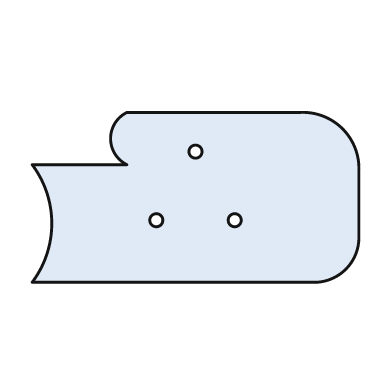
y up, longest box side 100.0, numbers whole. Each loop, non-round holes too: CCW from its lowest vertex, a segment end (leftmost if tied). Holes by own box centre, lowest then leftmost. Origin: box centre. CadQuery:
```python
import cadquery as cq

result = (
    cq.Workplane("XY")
    .moveTo(-50.0, -26.0)
    .lineTo(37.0, -26.0)
    .threePointArc((46.0, -22.0), (50.0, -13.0))
    .lineTo(50.0, 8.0)
    .threePointArc((45.0, 21.0), (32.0, 26.0))
    .lineTo(-21.0, 26.0)
    .threePointArc((-26.0, 18.0), (-21.0, 10.0))
    .lineTo(-50.0, 10.0)
    .threePointArc((-44.0, -8.0), (-50.0, -26.0))
    .close()
    .moveTo(-12.0, -7.0)
    .circle(2.0)
    .moveTo(12.0, -7.0)
    .circle(2.0)
    .moveTo(0.0, 14.0)
    .circle(2.0)
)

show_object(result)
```